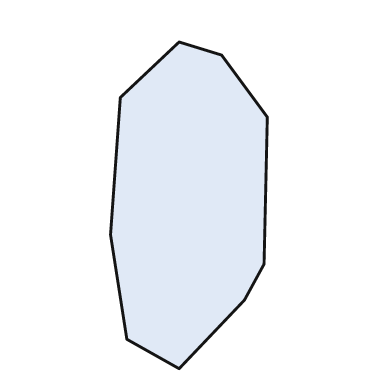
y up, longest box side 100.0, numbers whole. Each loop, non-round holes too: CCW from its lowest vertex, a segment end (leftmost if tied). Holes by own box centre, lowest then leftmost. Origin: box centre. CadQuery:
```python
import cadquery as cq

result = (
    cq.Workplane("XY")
    .moveTo(-3.0, -50.0)
    .lineTo(17.0, -29.0)
    .lineTo(23.0, -18.0)
    .lineTo(24.0, 27.0)
    .lineTo(10.0, 46.0)
    .lineTo(-3.0, 50.0)
    .lineTo(-21.0, 33.0)
    .lineTo(-24.0, -9.0)
    .lineTo(-19.0, -41.0)
    .close()
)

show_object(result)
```